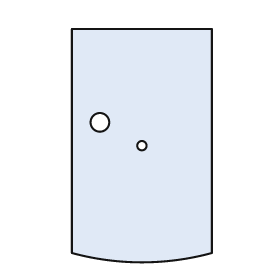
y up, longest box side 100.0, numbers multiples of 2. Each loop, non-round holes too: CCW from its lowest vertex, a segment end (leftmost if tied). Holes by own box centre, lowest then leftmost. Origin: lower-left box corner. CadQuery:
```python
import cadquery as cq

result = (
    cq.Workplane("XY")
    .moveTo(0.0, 4.0)
    .threePointArc((30.0, 0.0), (60.0, 4.0))
    .lineTo(60.0, 100.0)
    .lineTo(0.0, 100.0)
    .close()
    .moveTo(30.0, 50.0)
    .circle(2.0)
    .moveTo(12.0, 60.0)
    .circle(4.0)
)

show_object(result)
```